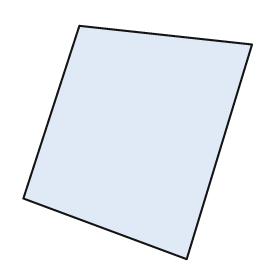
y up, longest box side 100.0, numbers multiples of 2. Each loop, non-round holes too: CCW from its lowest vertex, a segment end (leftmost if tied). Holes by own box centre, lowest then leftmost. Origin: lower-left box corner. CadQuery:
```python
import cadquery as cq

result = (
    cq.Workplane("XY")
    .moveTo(70.0, 0.0)
    .lineTo(98.0, 92.0)
    .lineTo(24.0, 100.0)
    .lineTo(0.0, 26.0)
    .close()
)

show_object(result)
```